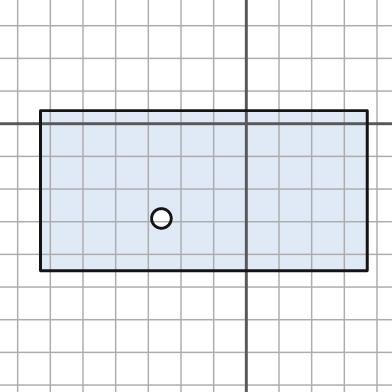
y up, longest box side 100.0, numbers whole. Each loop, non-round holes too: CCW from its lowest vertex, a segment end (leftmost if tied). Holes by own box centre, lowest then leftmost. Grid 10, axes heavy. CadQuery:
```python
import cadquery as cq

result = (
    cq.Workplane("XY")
    .moveTo(-63.0, -45.0)
    .lineTo(37.0, -45.0)
    .lineTo(37.0, 4.0)
    .lineTo(-63.0, 4.0)
    .close()
    .moveTo(-26.0, -29.0)
    .circle(3.0)
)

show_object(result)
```